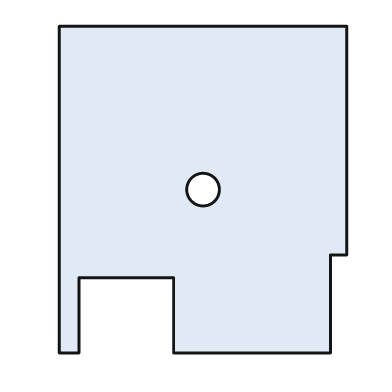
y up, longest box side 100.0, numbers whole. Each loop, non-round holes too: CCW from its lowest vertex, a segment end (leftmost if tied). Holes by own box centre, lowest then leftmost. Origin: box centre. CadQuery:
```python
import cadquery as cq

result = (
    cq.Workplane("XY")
    .moveTo(-44.0, -50.0)
    .lineTo(-38.0, -50.0)
    .lineTo(-38.0, -27.0)
    .lineTo(-9.0, -27.0)
    .lineTo(-9.0, -50.0)
    .lineTo(39.0, -50.0)
    .lineTo(39.0, -20.0)
    .lineTo(44.0, -20.0)
    .lineTo(44.0, 50.0)
    .lineTo(-44.0, 50.0)
    .close()
    .moveTo(0.0, 0.0)
    .circle(5.0)
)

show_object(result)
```